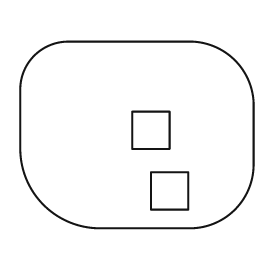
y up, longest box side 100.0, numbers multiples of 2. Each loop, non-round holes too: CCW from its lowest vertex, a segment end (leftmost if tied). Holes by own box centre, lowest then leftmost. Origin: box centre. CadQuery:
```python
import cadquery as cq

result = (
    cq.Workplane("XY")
    .moveTo(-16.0, -40.0)
    .lineTo(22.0, -40.0)
    .threePointArc((42.0, -32.0), (50.0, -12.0))
    .lineTo(50.0, 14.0)
    .threePointArc((42.0, 32.0), (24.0, 40.0))
    .lineTo(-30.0, 40.0)
    .threePointArc((-44.0, 34.0), (-50.0, 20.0))
    .lineTo(-50.0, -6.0)
    .threePointArc((-40.0, -30.0), (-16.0, -40.0))
    .close()
    .moveTo(6.0, -32.0)
    .lineTo(22.0, -32.0)
    .lineTo(22.0, -16.0)
    .lineTo(6.0, -16.0)
    .close()
    .moveTo(-2.0, -6.0)
    .lineTo(14.0, -6.0)
    .lineTo(14.0, 10.0)
    .lineTo(-2.0, 10.0)
    .close()
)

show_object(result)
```